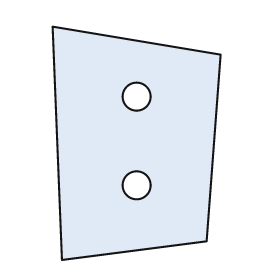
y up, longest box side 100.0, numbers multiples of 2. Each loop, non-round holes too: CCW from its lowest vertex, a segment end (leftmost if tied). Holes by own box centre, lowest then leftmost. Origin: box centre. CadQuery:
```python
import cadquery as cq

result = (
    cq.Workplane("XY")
    .moveTo(-32.0, -50.0)
    .lineTo(30.0, -42.0)
    .lineTo(36.0, 38.0)
    .lineTo(-36.0, 50.0)
    .close()
    .moveTo(0.0, -18.0)
    .circle(6.0)
    .moveTo(0.0, 20.0)
    .circle(6.0)
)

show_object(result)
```